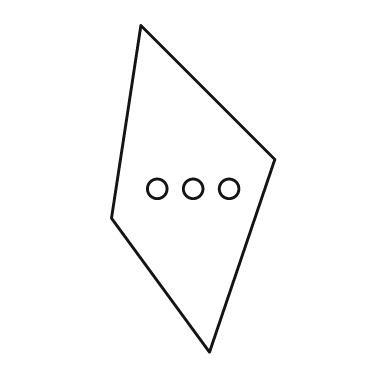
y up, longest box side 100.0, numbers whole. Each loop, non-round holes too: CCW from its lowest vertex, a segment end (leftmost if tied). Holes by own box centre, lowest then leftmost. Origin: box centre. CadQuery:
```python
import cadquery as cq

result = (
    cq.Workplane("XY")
    .moveTo(5.0, -50.0)
    .lineTo(25.0, 9.0)
    .lineTo(-16.0, 50.0)
    .lineTo(-25.0, -9.0)
    .close()
    .moveTo(-11.0, 0.0)
    .circle(3.0)
    .moveTo(0.0, 0.0)
    .circle(3.0)
    .moveTo(11.0, 0.0)
    .circle(3.0)
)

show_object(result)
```